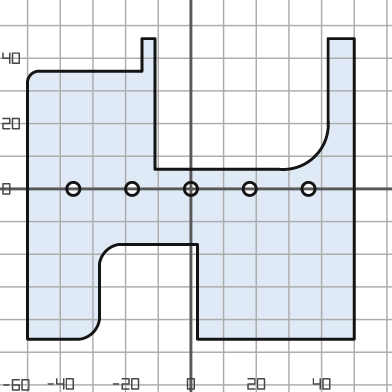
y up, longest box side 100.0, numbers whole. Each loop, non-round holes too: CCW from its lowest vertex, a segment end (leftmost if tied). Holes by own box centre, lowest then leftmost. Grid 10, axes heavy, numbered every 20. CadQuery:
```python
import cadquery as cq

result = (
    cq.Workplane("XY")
    .moveTo(-50.0, -46.0)
    .lineTo(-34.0, -46.0)
    .threePointArc((-30.0, -44.0), (-28.0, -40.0))
    .lineTo(-28.0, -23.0)
    .threePointArc((-26.0, -19.0), (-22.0, -17.0))
    .lineTo(2.0, -17.0)
    .lineTo(2.0, -46.0)
    .lineTo(50.0, -46.0)
    .lineTo(50.0, 46.0)
    .lineTo(42.0, 46.0)
    .lineTo(42.0, 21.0)
    .threePointArc((38.0, 10.0), (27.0, 6.0))
    .lineTo(-11.0, 6.0)
    .lineTo(-11.0, 46.0)
    .lineTo(-15.0, 46.0)
    .lineTo(-15.0, 36.0)
    .lineTo(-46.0, 36.0)
    .threePointArc((-49.0, 35.0), (-50.0, 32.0))
    .close()
    .moveTo(-36.0, 0.0)
    .circle(2.0)
    .moveTo(-18.0, 0.0)
    .circle(2.0)
    .moveTo(0.0, 0.0)
    .circle(2.0)
    .moveTo(18.0, 0.0)
    .circle(2.0)
    .moveTo(36.0, 0.0)
    .circle(2.0)
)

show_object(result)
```